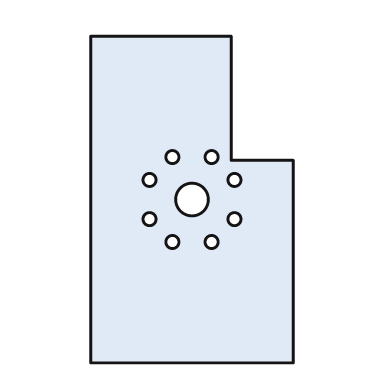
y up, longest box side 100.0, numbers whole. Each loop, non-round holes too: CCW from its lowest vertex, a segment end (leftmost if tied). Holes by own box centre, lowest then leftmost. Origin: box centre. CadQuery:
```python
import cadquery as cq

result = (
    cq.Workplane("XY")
    .moveTo(-31.0, -50.0)
    .lineTo(31.0, -50.0)
    .lineTo(31.0, 12.0)
    .lineTo(12.0, 12.0)
    .lineTo(12.0, 50.0)
    .lineTo(-31.0, 50.0)
    .close()
    .moveTo(-6.0, -13.0)
    .circle(2.0)
    .moveTo(6.0, -13.0)
    .circle(2.0)
    .moveTo(-13.0, -6.0)
    .circle(2.0)
    .moveTo(13.0, -6.0)
    .circle(2.0)
    .moveTo(0.0, 0.0)
    .circle(5.0)
    .moveTo(-13.0, 6.0)
    .circle(2.0)
    .moveTo(13.0, 6.0)
    .circle(2.0)
    .moveTo(-6.0, 13.0)
    .circle(2.0)
    .moveTo(6.0, 13.0)
    .circle(2.0)
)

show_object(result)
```